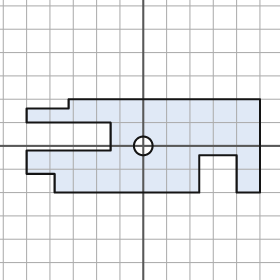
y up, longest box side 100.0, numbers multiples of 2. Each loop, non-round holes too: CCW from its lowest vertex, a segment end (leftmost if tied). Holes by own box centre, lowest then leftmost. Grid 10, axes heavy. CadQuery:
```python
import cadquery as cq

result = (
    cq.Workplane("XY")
    .moveTo(-38.0, -20.0)
    .lineTo(24.0, -20.0)
    .lineTo(24.0, -4.0)
    .lineTo(40.0, -4.0)
    .lineTo(40.0, -20.0)
    .lineTo(50.0, -20.0)
    .lineTo(50.0, 20.0)
    .lineTo(-32.0, 20.0)
    .lineTo(-32.0, 16.0)
    .lineTo(-50.0, 16.0)
    .lineTo(-50.0, 10.0)
    .lineTo(-14.0, 10.0)
    .lineTo(-14.0, -2.0)
    .lineTo(-50.0, -2.0)
    .lineTo(-50.0, -12.0)
    .lineTo(-38.0, -12.0)
    .close()
    .moveTo(0.0, 0.0)
    .circle(4.0)
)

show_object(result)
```